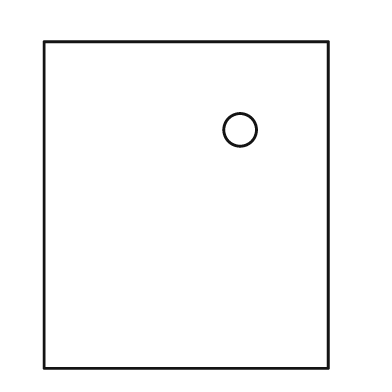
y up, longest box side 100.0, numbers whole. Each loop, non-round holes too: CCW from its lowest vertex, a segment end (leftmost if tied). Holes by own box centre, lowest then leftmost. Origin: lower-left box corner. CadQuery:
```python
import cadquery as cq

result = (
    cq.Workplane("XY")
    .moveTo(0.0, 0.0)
    .lineTo(87.0, 0.0)
    .lineTo(87.0, 100.0)
    .lineTo(0.0, 100.0)
    .close()
    .moveTo(60.0, 73.0)
    .circle(5.0)
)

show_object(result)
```